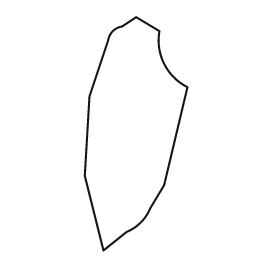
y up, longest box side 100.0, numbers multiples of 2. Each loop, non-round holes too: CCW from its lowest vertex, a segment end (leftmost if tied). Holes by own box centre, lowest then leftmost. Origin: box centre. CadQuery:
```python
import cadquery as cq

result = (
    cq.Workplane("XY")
    .moveTo(-14.0, -50.0)
    .lineTo(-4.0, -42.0)
    .threePointArc((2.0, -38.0), (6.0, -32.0))
    .lineTo(12.0, -22.0)
    .lineTo(22.0, 20.0)
    .threePointArc((12.0, 30.0), (10.0, 44.0))
    .lineTo(0.0, 50.0)
    .lineTo(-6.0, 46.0)
    .threePointArc((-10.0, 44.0), (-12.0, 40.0))
    .lineTo(-20.0, 16.0)
    .lineTo(-22.0, -18.0)
    .close()
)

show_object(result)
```